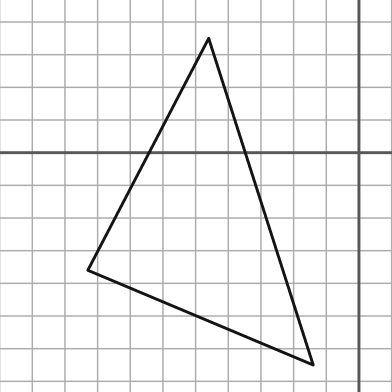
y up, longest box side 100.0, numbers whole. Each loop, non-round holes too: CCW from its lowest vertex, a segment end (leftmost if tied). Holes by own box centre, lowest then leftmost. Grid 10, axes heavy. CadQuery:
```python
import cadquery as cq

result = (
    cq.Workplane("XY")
    .moveTo(-14.0, -65.0)
    .lineTo(-46.0, 35.0)
    .lineTo(-83.0, -36.0)
    .close()
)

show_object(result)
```